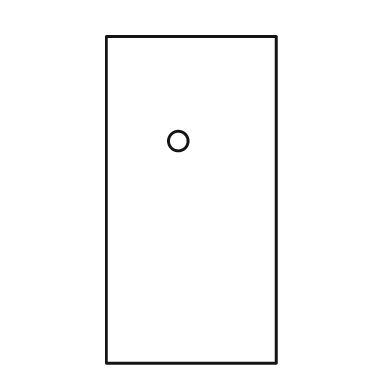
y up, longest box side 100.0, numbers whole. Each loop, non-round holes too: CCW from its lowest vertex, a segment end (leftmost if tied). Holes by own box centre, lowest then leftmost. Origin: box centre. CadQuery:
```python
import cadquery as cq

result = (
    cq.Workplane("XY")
    .moveTo(-26.0, -50.0)
    .lineTo(26.0, -50.0)
    .lineTo(26.0, 50.0)
    .lineTo(-26.0, 50.0)
    .close()
    .moveTo(-4.0, 18.0)
    .circle(3.0)
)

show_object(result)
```